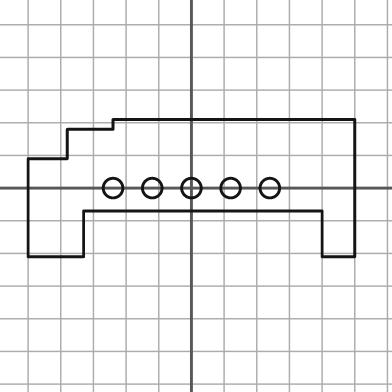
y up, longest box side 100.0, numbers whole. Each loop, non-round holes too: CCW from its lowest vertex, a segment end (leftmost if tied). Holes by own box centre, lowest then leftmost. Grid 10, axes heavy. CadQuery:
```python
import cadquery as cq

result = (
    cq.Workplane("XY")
    .moveTo(-50.0, -21.0)
    .lineTo(-33.0, -21.0)
    .lineTo(-33.0, -7.0)
    .lineTo(40.0, -7.0)
    .lineTo(40.0, -21.0)
    .lineTo(50.0, -21.0)
    .lineTo(50.0, 21.0)
    .lineTo(-24.0, 21.0)
    .lineTo(-24.0, 18.0)
    .lineTo(-38.0, 18.0)
    .lineTo(-38.0, 9.0)
    .lineTo(-50.0, 9.0)
    .close()
    .moveTo(-24.0, 0.0)
    .circle(3.0)
    .moveTo(-12.0, 0.0)
    .circle(3.0)
    .moveTo(0.0, 0.0)
    .circle(3.0)
    .moveTo(12.0, 0.0)
    .circle(3.0)
    .moveTo(24.0, 0.0)
    .circle(3.0)
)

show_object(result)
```